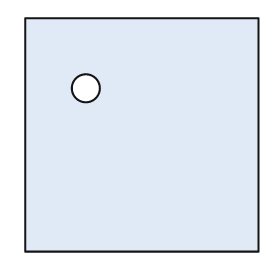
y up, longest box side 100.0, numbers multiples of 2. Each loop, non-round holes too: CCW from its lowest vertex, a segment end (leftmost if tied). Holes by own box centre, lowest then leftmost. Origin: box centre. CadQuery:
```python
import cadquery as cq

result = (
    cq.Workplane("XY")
    .moveTo(-50.0, -50.0)
    .lineTo(50.0, -50.0)
    .lineTo(50.0, 50.0)
    .lineTo(-50.0, 50.0)
    .close()
    .moveTo(-24.0, 20.0)
    .circle(6.0)
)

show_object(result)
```